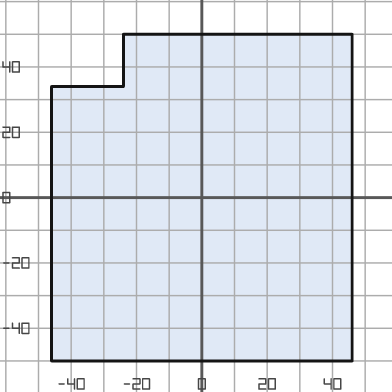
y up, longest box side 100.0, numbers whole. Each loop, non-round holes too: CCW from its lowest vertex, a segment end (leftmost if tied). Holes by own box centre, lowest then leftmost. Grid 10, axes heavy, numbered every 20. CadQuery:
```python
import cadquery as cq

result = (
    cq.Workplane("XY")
    .moveTo(-46.0, -50.0)
    .lineTo(46.0, -50.0)
    .lineTo(46.0, 50.0)
    .lineTo(-24.0, 50.0)
    .lineTo(-24.0, 34.0)
    .lineTo(-46.0, 34.0)
    .close()
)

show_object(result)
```